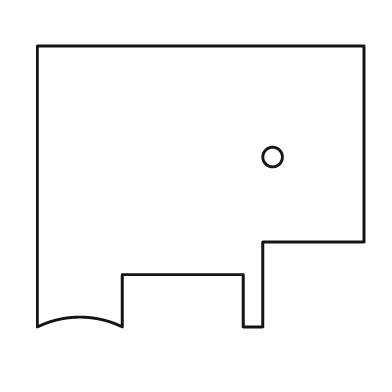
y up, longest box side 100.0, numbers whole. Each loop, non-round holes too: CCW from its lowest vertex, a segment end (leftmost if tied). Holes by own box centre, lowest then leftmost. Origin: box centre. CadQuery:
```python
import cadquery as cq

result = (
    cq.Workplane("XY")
    .moveTo(-50.0, -43.0)
    .threePointArc((-37.0, -40.0), (-24.0, -43.0))
    .lineTo(-24.0, -27.0)
    .lineTo(13.0, -27.0)
    .lineTo(13.0, -43.0)
    .lineTo(19.0, -43.0)
    .lineTo(19.0, -17.0)
    .lineTo(50.0, -17.0)
    .lineTo(50.0, 43.0)
    .lineTo(-50.0, 43.0)
    .close()
    .moveTo(22.0, 9.0)
    .circle(3.0)
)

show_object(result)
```